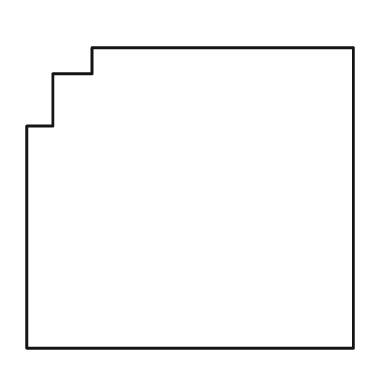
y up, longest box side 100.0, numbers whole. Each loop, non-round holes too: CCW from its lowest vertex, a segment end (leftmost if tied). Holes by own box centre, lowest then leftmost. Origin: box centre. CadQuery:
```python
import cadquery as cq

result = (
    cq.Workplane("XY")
    .moveTo(-50.0, -46.0)
    .lineTo(50.0, -46.0)
    .lineTo(50.0, 46.0)
    .lineTo(-30.0, 46.0)
    .lineTo(-30.0, 38.0)
    .lineTo(-42.0, 38.0)
    .lineTo(-42.0, 22.0)
    .lineTo(-50.0, 22.0)
    .close()
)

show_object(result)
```